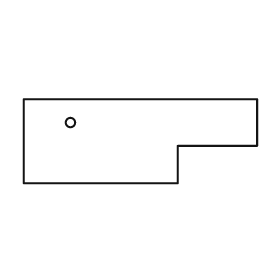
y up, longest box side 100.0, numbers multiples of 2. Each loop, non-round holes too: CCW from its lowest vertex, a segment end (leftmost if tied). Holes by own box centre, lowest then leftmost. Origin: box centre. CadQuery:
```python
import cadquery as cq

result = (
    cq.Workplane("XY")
    .moveTo(-50.0, -18.0)
    .lineTo(16.0, -18.0)
    .lineTo(16.0, -2.0)
    .lineTo(50.0, -2.0)
    .lineTo(50.0, 18.0)
    .lineTo(-50.0, 18.0)
    .close()
    .moveTo(-30.0, 8.0)
    .circle(2.0)
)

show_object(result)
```